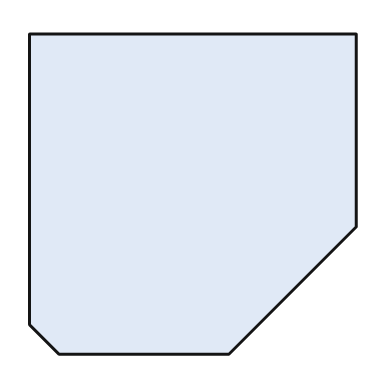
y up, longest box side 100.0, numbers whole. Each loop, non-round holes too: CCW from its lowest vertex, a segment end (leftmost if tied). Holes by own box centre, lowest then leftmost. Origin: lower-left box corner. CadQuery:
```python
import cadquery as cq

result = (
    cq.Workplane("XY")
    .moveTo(9.0, 0.0)
    .lineTo(61.0, 0.0)
    .lineTo(100.0, 39.0)
    .lineTo(100.0, 98.0)
    .lineTo(0.0, 98.0)
    .lineTo(0.0, 9.0)
    .close()
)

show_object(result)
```